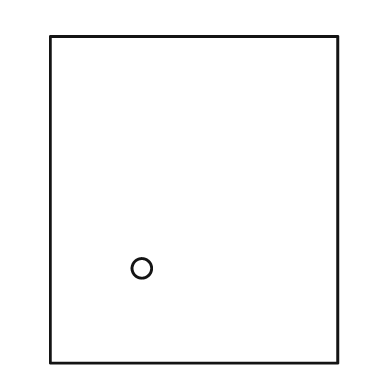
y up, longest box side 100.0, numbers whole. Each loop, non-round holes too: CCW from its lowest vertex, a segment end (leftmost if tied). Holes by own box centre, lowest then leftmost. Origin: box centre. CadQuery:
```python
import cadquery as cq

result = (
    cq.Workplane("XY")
    .moveTo(-44.0, -50.0)
    .lineTo(44.0, -50.0)
    .lineTo(44.0, 50.0)
    .lineTo(-44.0, 50.0)
    .close()
    .moveTo(-16.0, -21.0)
    .circle(3.0)
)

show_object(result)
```